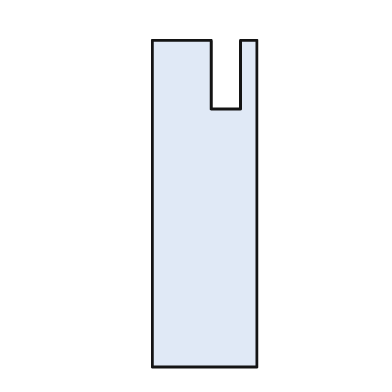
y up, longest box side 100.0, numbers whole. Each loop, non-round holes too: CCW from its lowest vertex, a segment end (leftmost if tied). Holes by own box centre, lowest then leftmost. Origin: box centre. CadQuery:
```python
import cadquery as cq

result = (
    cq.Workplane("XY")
    .moveTo(-16.0, -50.0)
    .lineTo(16.0, -50.0)
    .lineTo(16.0, 50.0)
    .lineTo(11.0, 50.0)
    .lineTo(11.0, 29.0)
    .lineTo(2.0, 29.0)
    .lineTo(2.0, 50.0)
    .lineTo(-16.0, 50.0)
    .close()
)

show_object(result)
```